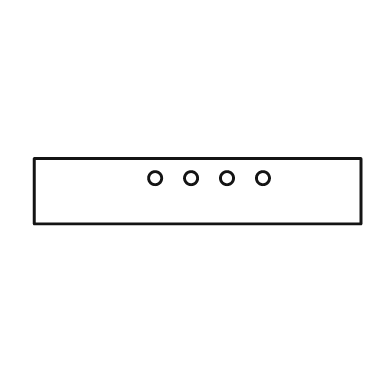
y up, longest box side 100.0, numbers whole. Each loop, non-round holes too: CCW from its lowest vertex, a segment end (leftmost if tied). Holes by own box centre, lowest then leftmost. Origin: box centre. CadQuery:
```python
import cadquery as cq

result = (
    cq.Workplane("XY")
    .moveTo(-50.0, -10.0)
    .lineTo(50.0, -10.0)
    .lineTo(50.0, 10.0)
    .lineTo(-50.0, 10.0)
    .close()
    .moveTo(-13.0, 4.0)
    .circle(2.0)
    .moveTo(-2.0, 4.0)
    .circle(2.0)
    .moveTo(9.0, 4.0)
    .circle(2.0)
    .moveTo(20.0, 4.0)
    .circle(2.0)
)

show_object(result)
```